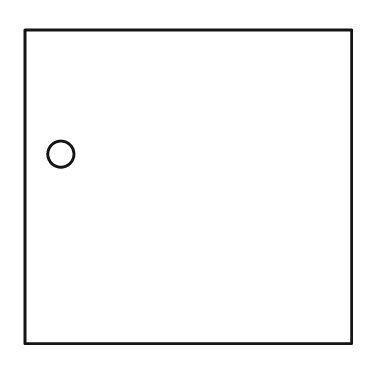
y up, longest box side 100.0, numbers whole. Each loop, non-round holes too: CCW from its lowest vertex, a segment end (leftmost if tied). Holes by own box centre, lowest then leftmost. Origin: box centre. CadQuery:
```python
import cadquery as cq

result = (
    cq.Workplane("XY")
    .moveTo(-50.0, -48.0)
    .lineTo(50.0, -48.0)
    .lineTo(50.0, 48.0)
    .lineTo(-50.0, 48.0)
    .close()
    .moveTo(-39.0, 10.0)
    .circle(4.0)
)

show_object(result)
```